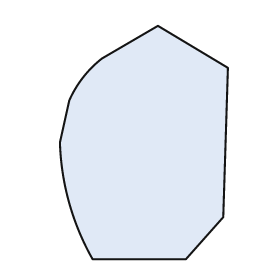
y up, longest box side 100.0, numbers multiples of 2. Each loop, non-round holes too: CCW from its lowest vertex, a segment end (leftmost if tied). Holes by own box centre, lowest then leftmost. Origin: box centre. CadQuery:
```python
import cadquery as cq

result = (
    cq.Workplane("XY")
    .moveTo(-22.0, -50.0)
    .lineTo(18.0, -50.0)
    .lineTo(34.0, -32.0)
    .lineTo(36.0, 32.0)
    .lineTo(6.0, 50.0)
    .lineTo(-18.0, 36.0)
    .threePointArc((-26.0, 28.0), (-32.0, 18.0))
    .lineTo(-36.0, 0.0)
    .threePointArc((-32.0, -26.0), (-22.0, -50.0))
    .close()
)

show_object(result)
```